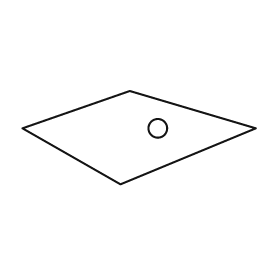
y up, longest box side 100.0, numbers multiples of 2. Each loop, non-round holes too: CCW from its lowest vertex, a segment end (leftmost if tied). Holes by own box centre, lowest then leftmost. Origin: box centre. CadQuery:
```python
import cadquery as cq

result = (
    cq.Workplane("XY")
    .moveTo(-8.0, -20.0)
    .lineTo(50.0, 4.0)
    .lineTo(-4.0, 20.0)
    .lineTo(-50.0, 4.0)
    .close()
    .moveTo(8.0, 4.0)
    .circle(4.0)
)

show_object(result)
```